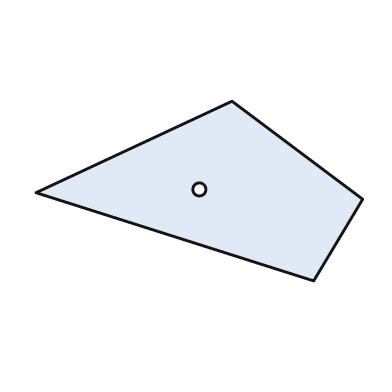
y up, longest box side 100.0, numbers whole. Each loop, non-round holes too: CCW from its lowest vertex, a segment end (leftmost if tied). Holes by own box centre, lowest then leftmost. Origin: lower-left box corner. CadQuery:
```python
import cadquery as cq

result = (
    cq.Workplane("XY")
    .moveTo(85.0, 0.0)
    .lineTo(100.0, 25.0)
    .lineTo(60.0, 55.0)
    .lineTo(0.0, 27.0)
    .close()
    .moveTo(50.0, 28.0)
    .circle(2.0)
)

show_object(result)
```